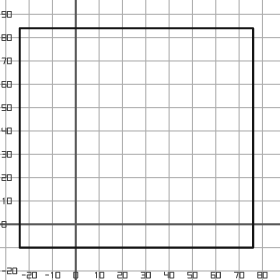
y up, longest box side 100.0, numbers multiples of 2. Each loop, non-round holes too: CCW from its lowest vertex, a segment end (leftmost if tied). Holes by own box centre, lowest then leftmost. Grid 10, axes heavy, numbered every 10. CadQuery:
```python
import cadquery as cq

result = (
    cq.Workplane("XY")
    .moveTo(-24.0, -10.0)
    .lineTo(76.0, -10.0)
    .lineTo(76.0, 84.0)
    .lineTo(-24.0, 84.0)
    .close()
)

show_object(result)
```